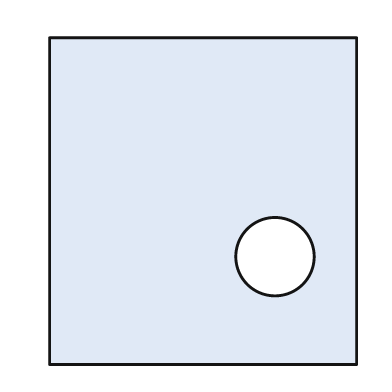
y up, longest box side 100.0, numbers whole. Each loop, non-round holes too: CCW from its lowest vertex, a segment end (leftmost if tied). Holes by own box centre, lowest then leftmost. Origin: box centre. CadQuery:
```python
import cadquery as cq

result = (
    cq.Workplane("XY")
    .moveTo(-47.0, -50.0)
    .lineTo(47.0, -50.0)
    .lineTo(47.0, 50.0)
    .lineTo(-47.0, 50.0)
    .close()
    .moveTo(22.0, -17.0)
    .circle(12.0)
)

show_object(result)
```